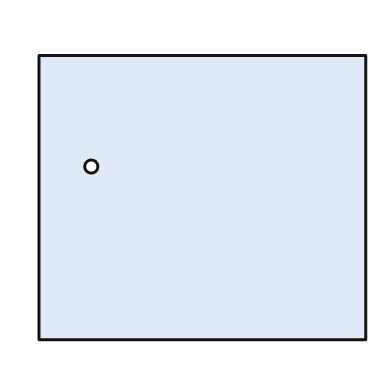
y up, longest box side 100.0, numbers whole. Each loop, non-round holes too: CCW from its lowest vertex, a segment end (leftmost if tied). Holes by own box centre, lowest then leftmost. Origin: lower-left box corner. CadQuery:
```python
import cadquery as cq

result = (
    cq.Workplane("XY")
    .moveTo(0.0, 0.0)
    .lineTo(100.0, 0.0)
    .lineTo(100.0, 87.0)
    .lineTo(0.0, 87.0)
    .close()
    .moveTo(16.0, 53.0)
    .circle(2.0)
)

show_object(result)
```